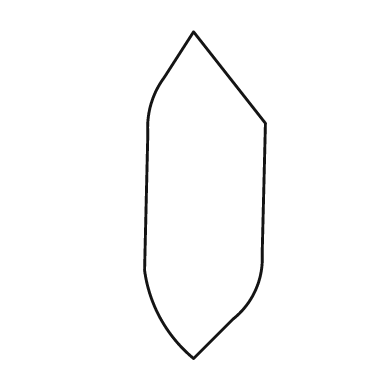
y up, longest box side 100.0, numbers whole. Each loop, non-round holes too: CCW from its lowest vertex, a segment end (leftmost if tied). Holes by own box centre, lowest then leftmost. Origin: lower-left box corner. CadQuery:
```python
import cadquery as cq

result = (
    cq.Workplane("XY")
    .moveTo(15.0, 0.0)
    .lineTo(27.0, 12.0)
    .threePointArc((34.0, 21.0), (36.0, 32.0))
    .lineTo(37.0, 72.0)
    .lineTo(15.0, 100.0)
    .lineTo(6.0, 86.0)
    .threePointArc((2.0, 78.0), (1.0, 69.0))
    .lineTo(0.0, 27.0)
    .threePointArc((5.0, 12.0), (15.0, 0.0))
    .close()
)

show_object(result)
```